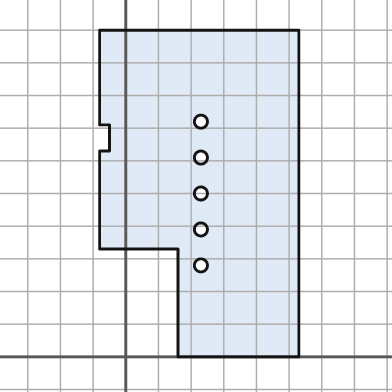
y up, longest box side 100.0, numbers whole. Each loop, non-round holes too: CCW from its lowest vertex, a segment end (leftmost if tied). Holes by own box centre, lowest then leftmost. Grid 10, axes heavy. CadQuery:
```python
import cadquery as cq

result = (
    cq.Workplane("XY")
    .moveTo(16.0, 0.0)
    .lineTo(53.0, 0.0)
    .lineTo(53.0, 100.0)
    .lineTo(-8.0, 100.0)
    .lineTo(-8.0, 71.0)
    .lineTo(-5.0, 71.0)
    .lineTo(-5.0, 63.0)
    .lineTo(-8.0, 63.0)
    .lineTo(-8.0, 33.0)
    .lineTo(16.0, 33.0)
    .close()
    .moveTo(23.0, 28.0)
    .circle(2.0)
    .moveTo(23.0, 39.0)
    .circle(2.0)
    .moveTo(23.0, 50.0)
    .circle(2.0)
    .moveTo(23.0, 61.0)
    .circle(2.0)
    .moveTo(23.0, 72.0)
    .circle(2.0)
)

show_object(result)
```